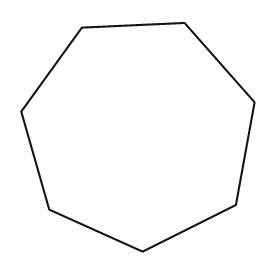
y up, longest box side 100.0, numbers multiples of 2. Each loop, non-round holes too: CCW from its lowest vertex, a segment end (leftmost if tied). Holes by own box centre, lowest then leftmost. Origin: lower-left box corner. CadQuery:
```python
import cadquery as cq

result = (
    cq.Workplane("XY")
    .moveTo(52.0, 0.0)
    .lineTo(92.0, 20.0)
    .lineTo(100.0, 64.0)
    .lineTo(70.0, 98.0)
    .lineTo(26.0, 96.0)
    .lineTo(0.0, 60.0)
    .lineTo(12.0, 18.0)
    .close()
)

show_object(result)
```